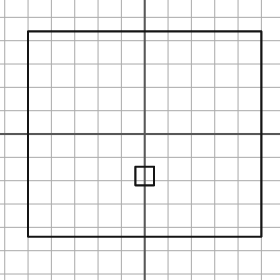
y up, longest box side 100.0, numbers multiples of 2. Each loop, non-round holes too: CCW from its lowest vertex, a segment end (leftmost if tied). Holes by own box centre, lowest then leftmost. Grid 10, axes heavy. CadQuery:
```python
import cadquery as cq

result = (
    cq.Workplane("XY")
    .moveTo(-50.0, -44.0)
    .lineTo(50.0, -44.0)
    .lineTo(50.0, 44.0)
    .lineTo(-50.0, 44.0)
    .close()
    .moveTo(-4.0, -22.0)
    .lineTo(4.0, -22.0)
    .lineTo(4.0, -14.0)
    .lineTo(-4.0, -14.0)
    .close()
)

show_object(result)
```